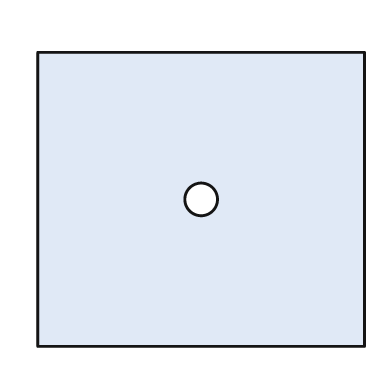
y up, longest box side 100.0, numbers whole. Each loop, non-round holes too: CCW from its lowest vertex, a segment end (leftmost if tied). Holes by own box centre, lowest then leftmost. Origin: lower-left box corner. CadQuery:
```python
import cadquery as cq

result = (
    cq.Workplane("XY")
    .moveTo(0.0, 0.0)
    .lineTo(100.0, 0.0)
    .lineTo(100.0, 90.0)
    .lineTo(0.0, 90.0)
    .close()
    .moveTo(50.0, 45.0)
    .circle(5.0)
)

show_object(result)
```